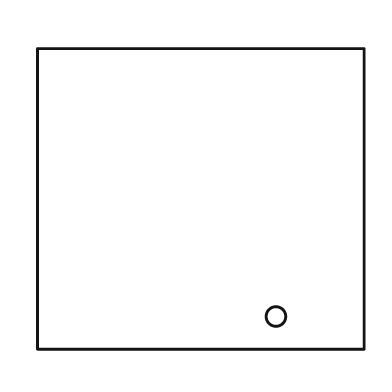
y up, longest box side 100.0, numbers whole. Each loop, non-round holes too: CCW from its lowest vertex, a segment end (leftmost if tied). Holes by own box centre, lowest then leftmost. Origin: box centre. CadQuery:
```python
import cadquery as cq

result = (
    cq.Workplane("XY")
    .moveTo(-50.0, -46.0)
    .lineTo(50.0, -46.0)
    .lineTo(50.0, 46.0)
    .lineTo(-50.0, 46.0)
    .close()
    .moveTo(23.0, -36.0)
    .circle(3.0)
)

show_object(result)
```